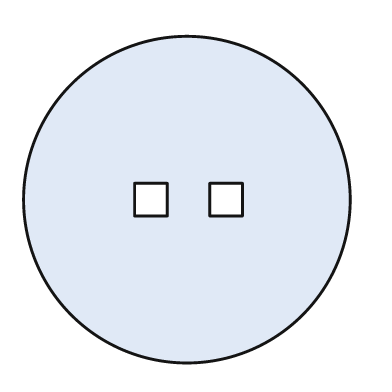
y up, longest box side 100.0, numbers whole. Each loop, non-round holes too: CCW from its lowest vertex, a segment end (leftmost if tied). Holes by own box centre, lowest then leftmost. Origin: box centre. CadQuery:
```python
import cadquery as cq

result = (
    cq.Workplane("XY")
    .moveTo(0.0, 0.0)
    .circle(50.0)
    .moveTo(-16.0, -5.0)
    .lineTo(-6.0, -5.0)
    .lineTo(-6.0, 5.0)
    .lineTo(-16.0, 5.0)
    .close()
    .moveTo(7.0, -5.0)
    .lineTo(17.0, -5.0)
    .lineTo(17.0, 5.0)
    .lineTo(7.0, 5.0)
    .close()
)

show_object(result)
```